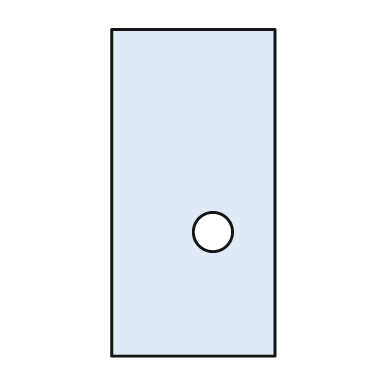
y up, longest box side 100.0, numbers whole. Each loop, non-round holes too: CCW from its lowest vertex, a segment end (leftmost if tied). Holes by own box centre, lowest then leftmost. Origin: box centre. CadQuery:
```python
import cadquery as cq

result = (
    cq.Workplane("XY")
    .moveTo(-25.0, -50.0)
    .lineTo(25.0, -50.0)
    .lineTo(25.0, 50.0)
    .lineTo(-25.0, 50.0)
    .close()
    .moveTo(6.0, -12.0)
    .circle(6.0)
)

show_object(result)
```